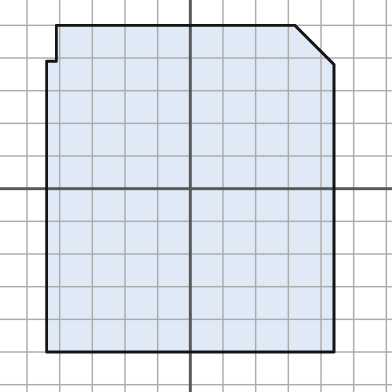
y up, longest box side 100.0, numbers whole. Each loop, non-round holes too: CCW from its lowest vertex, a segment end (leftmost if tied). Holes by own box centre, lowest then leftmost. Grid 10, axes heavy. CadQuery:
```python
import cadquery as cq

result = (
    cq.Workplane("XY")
    .moveTo(-44.0, -50.0)
    .lineTo(44.0, -50.0)
    .lineTo(44.0, 38.0)
    .lineTo(32.0, 50.0)
    .lineTo(-41.0, 50.0)
    .lineTo(-41.0, 39.0)
    .lineTo(-44.0, 39.0)
    .close()
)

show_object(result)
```